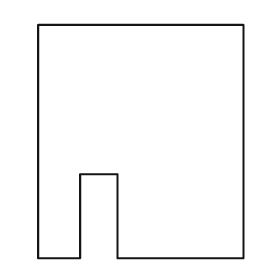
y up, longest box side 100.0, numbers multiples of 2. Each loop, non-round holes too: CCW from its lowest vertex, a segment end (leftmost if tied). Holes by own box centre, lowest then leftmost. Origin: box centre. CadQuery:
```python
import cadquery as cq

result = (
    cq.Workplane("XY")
    .moveTo(-44.0, -50.0)
    .lineTo(-26.0, -50.0)
    .lineTo(-26.0, -14.0)
    .lineTo(-10.0, -14.0)
    .lineTo(-10.0, -50.0)
    .lineTo(44.0, -50.0)
    .lineTo(44.0, 50.0)
    .lineTo(-44.0, 50.0)
    .close()
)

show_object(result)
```